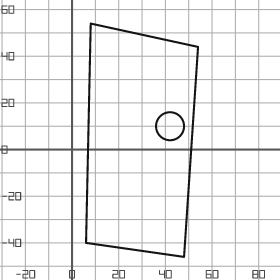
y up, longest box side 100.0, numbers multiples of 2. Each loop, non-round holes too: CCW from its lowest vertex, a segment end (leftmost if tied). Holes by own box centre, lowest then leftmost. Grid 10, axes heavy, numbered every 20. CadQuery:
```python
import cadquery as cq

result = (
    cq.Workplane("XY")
    .moveTo(48.0, -46.0)
    .lineTo(54.0, 44.0)
    .lineTo(8.0, 54.0)
    .lineTo(6.0, -40.0)
    .close()
    .moveTo(42.0, 10.0)
    .circle(6.0)
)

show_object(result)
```